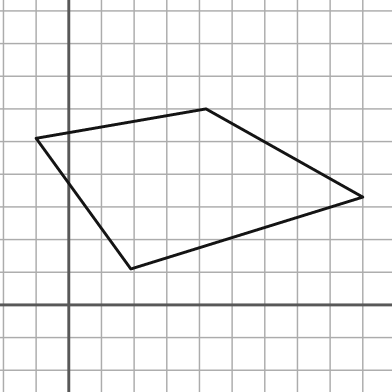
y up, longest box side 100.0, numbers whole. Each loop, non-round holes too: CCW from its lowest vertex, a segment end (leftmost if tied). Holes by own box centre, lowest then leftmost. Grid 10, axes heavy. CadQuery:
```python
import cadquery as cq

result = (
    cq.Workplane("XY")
    .moveTo(19.0, 11.0)
    .lineTo(90.0, 33.0)
    .lineTo(42.0, 60.0)
    .lineTo(-10.0, 51.0)
    .close()
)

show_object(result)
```